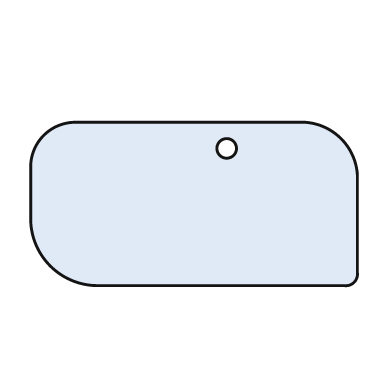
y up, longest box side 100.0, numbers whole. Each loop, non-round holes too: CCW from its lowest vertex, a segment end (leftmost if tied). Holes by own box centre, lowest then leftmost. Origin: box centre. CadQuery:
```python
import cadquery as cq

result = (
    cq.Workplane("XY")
    .moveTo(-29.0, -25.0)
    .lineTo(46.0, -25.0)
    .threePointArc((49.0, -24.0), (50.0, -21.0))
    .lineTo(50.0, 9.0)
    .threePointArc((45.0, 20.0), (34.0, 25.0))
    .lineTo(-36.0, 25.0)
    .threePointArc((-46.0, 21.0), (-50.0, 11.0))
    .lineTo(-50.0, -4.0)
    .threePointArc((-44.0, -19.0), (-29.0, -25.0))
    .close()
    .moveTo(10.0, 17.0)
    .circle(3.0)
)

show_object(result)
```